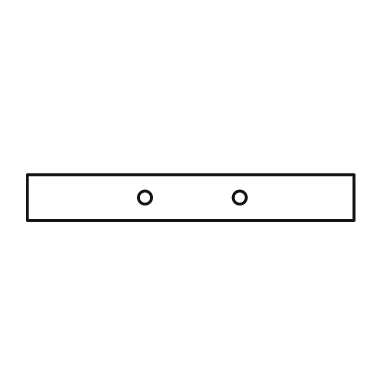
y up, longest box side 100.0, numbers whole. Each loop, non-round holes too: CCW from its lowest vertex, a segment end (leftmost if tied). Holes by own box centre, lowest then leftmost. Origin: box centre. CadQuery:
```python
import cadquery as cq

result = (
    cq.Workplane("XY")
    .moveTo(-50.0, -7.0)
    .lineTo(50.0, -7.0)
    .lineTo(50.0, 7.0)
    .lineTo(-50.0, 7.0)
    .close()
    .moveTo(-14.0, 0.0)
    .circle(2.0)
    .moveTo(15.0, 0.0)
    .circle(2.0)
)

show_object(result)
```